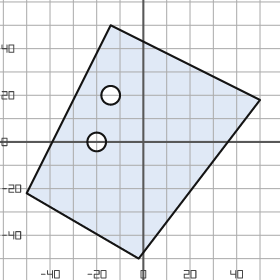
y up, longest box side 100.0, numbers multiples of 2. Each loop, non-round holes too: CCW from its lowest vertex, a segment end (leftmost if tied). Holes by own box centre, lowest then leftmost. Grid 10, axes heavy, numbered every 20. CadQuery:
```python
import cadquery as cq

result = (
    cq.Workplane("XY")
    .moveTo(-2.0, -50.0)
    .lineTo(50.0, 18.0)
    .lineTo(-14.0, 50.0)
    .lineTo(-50.0, -22.0)
    .close()
    .moveTo(-20.0, 0.0)
    .circle(4.0)
    .moveTo(-14.0, 20.0)
    .circle(4.0)
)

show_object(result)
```